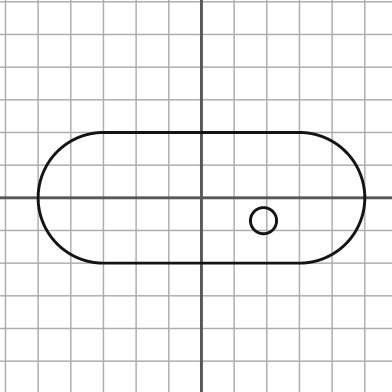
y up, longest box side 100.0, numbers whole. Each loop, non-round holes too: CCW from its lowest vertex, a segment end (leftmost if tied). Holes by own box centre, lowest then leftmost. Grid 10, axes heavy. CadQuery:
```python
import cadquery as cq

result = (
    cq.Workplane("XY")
    .moveTo(-30.0, -20.0)
    .lineTo(30.0, -20.0)
    .threePointArc((50.0, 0.0), (30.0, 20.0))
    .lineTo(-30.0, 20.0)
    .threePointArc((-50.0, 0.0), (-30.0, -20.0))
    .close()
    .moveTo(19.0, -7.0)
    .circle(4.0)
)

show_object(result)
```